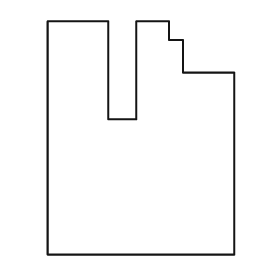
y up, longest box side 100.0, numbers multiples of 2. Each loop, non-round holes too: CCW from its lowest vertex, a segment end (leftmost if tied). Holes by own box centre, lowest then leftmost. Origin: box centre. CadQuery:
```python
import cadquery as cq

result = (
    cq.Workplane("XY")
    .moveTo(-40.0, -50.0)
    .lineTo(40.0, -50.0)
    .lineTo(40.0, 28.0)
    .lineTo(18.0, 28.0)
    .lineTo(18.0, 42.0)
    .lineTo(12.0, 42.0)
    .lineTo(12.0, 50.0)
    .lineTo(-2.0, 50.0)
    .lineTo(-2.0, 8.0)
    .lineTo(-14.0, 8.0)
    .lineTo(-14.0, 50.0)
    .lineTo(-40.0, 50.0)
    .close()
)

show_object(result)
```